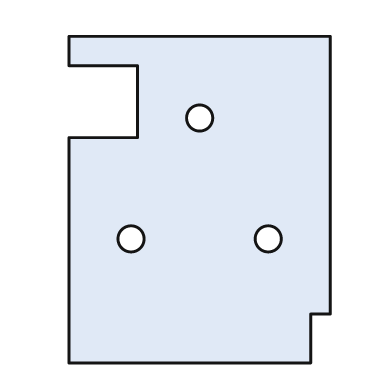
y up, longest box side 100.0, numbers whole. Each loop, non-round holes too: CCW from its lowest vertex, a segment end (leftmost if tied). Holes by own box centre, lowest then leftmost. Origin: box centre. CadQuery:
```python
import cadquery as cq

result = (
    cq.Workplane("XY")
    .moveTo(-40.0, -50.0)
    .lineTo(34.0, -50.0)
    .lineTo(34.0, -35.0)
    .lineTo(40.0, -35.0)
    .lineTo(40.0, 50.0)
    .lineTo(-40.0, 50.0)
    .lineTo(-40.0, 41.0)
    .lineTo(-19.0, 41.0)
    .lineTo(-19.0, 19.0)
    .lineTo(-40.0, 19.0)
    .close()
    .moveTo(-21.0, -12.0)
    .circle(4.0)
    .moveTo(21.0, -12.0)
    .circle(4.0)
    .moveTo(0.0, 25.0)
    .circle(4.0)
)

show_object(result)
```